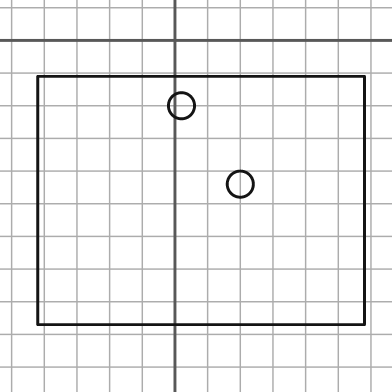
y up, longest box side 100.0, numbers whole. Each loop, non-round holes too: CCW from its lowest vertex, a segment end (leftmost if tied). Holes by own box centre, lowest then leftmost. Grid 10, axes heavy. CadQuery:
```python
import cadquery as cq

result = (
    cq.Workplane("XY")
    .moveTo(-42.0, -87.0)
    .lineTo(58.0, -87.0)
    .lineTo(58.0, -11.0)
    .lineTo(-42.0, -11.0)
    .close()
    .moveTo(20.0, -44.0)
    .circle(4.0)
    .moveTo(2.0, -20.0)
    .circle(4.0)
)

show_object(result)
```